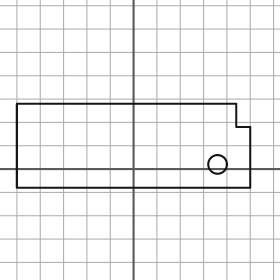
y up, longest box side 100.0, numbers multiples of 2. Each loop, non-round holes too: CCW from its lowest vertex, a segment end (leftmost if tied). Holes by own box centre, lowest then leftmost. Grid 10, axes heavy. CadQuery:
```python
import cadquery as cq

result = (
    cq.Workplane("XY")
    .moveTo(-50.0, -8.0)
    .lineTo(50.0, -8.0)
    .lineTo(50.0, 18.0)
    .lineTo(44.0, 18.0)
    .lineTo(44.0, 28.0)
    .lineTo(-50.0, 28.0)
    .close()
    .moveTo(36.0, 2.0)
    .circle(4.0)
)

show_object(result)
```